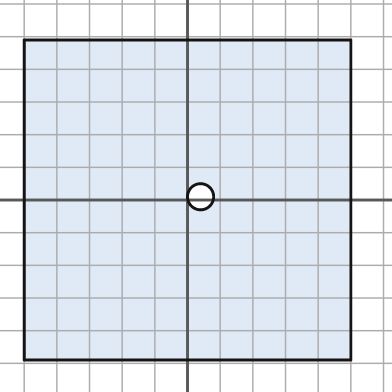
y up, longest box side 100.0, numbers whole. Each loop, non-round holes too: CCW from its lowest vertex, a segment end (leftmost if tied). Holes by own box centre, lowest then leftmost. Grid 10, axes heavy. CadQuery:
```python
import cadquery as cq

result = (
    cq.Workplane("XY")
    .moveTo(-50.0, -49.0)
    .lineTo(50.0, -49.0)
    .lineTo(50.0, 49.0)
    .lineTo(-50.0, 49.0)
    .close()
    .moveTo(4.0, 1.0)
    .circle(4.0)
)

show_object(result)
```